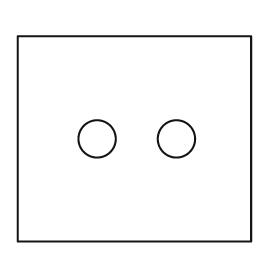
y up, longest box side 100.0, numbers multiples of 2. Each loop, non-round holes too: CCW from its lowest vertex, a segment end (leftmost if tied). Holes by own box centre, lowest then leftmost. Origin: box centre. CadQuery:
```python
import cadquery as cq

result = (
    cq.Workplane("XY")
    .moveTo(-50.0, -44.0)
    .lineTo(50.0, -44.0)
    .lineTo(50.0, 44.0)
    .lineTo(-50.0, 44.0)
    .close()
    .moveTo(-16.0, 0.0)
    .circle(8.0)
    .moveTo(18.0, 0.0)
    .circle(8.0)
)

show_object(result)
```